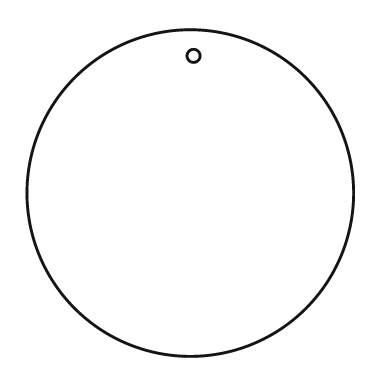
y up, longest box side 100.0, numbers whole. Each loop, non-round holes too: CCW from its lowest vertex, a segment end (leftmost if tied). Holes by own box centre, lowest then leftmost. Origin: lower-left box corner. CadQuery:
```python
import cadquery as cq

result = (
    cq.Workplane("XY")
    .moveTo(50.0, 50.0)
    .circle(50.0)
    .moveTo(51.0, 92.0)
    .circle(2.0)
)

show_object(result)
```